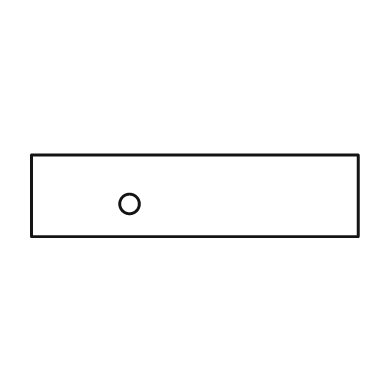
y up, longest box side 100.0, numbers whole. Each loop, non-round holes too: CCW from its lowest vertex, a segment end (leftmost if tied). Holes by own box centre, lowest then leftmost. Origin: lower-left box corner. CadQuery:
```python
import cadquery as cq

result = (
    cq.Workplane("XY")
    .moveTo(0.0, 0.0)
    .lineTo(100.0, 0.0)
    .lineTo(100.0, 25.0)
    .lineTo(0.0, 25.0)
    .close()
    .moveTo(30.0, 10.0)
    .circle(3.0)
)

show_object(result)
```